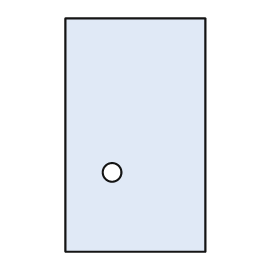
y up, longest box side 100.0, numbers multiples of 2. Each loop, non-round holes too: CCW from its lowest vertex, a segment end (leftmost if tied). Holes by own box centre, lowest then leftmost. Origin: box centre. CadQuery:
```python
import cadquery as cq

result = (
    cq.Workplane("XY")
    .moveTo(-30.0, -50.0)
    .lineTo(30.0, -50.0)
    .lineTo(30.0, 50.0)
    .lineTo(-30.0, 50.0)
    .close()
    .moveTo(-10.0, -16.0)
    .circle(4.0)
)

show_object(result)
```